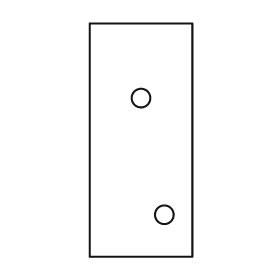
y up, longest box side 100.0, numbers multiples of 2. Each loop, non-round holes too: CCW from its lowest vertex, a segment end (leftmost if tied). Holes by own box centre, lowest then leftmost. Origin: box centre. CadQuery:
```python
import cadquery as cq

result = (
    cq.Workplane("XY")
    .moveTo(-22.0, -50.0)
    .lineTo(22.0, -50.0)
    .lineTo(22.0, 50.0)
    .lineTo(-22.0, 50.0)
    .close()
    .moveTo(10.0, -32.0)
    .circle(4.0)
    .moveTo(0.0, 18.0)
    .circle(4.0)
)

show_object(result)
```